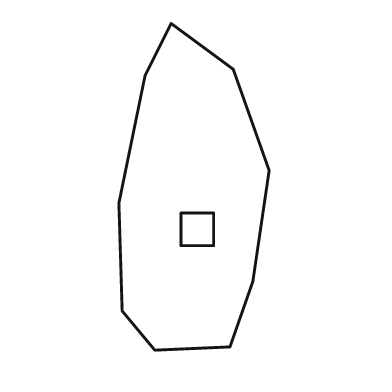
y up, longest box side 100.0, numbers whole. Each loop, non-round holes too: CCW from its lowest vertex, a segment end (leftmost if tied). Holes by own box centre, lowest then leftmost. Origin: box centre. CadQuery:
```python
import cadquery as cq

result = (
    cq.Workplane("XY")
    .moveTo(-12.0, -50.0)
    .lineTo(11.0, -49.0)
    .lineTo(18.0, -29.0)
    .lineTo(23.0, 5.0)
    .lineTo(12.0, 36.0)
    .lineTo(-7.0, 50.0)
    .lineTo(-15.0, 34.0)
    .lineTo(-23.0, -5.0)
    .lineTo(-22.0, -38.0)
    .close()
    .moveTo(-4.0, -18.0)
    .lineTo(6.0, -18.0)
    .lineTo(6.0, -8.0)
    .lineTo(-4.0, -8.0)
    .close()
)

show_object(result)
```